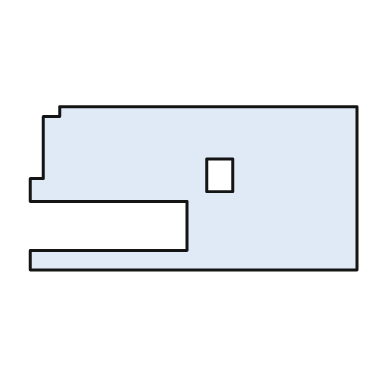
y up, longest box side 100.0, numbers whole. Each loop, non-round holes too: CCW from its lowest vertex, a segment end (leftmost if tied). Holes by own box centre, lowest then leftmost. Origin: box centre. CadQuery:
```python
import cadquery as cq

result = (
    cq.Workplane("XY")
    .moveTo(-50.0, -25.0)
    .lineTo(50.0, -25.0)
    .lineTo(50.0, 25.0)
    .lineTo(-41.0, 25.0)
    .lineTo(-41.0, 22.0)
    .lineTo(-46.0, 22.0)
    .lineTo(-46.0, 3.0)
    .lineTo(-50.0, 3.0)
    .lineTo(-50.0, -4.0)
    .lineTo(-2.0, -4.0)
    .lineTo(-2.0, -19.0)
    .lineTo(-50.0, -19.0)
    .close()
    .moveTo(4.0, -1.0)
    .lineTo(12.0, -1.0)
    .lineTo(12.0, 9.0)
    .lineTo(4.0, 9.0)
    .close()
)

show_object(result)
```